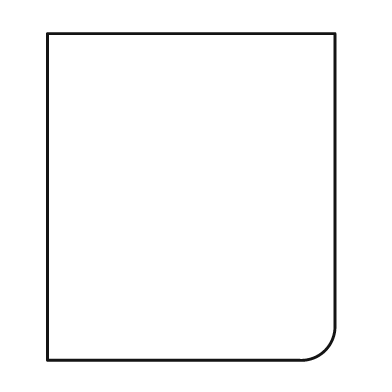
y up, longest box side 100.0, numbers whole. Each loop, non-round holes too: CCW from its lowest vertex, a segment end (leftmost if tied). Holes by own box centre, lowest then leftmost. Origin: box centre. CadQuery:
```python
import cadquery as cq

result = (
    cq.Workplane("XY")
    .moveTo(-44.0, -50.0)
    .lineTo(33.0, -50.0)
    .threePointArc((41.0, -47.0), (44.0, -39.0))
    .lineTo(44.0, 50.0)
    .lineTo(-44.0, 50.0)
    .close()
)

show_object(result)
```